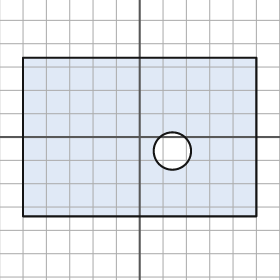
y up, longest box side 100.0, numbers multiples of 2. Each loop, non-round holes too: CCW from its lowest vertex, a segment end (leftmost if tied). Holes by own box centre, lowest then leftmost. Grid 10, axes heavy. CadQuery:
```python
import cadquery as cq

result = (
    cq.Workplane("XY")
    .moveTo(-50.0, -34.0)
    .lineTo(50.0, -34.0)
    .lineTo(50.0, 34.0)
    .lineTo(-50.0, 34.0)
    .close()
    .moveTo(14.0, -6.0)
    .circle(8.0)
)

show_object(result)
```